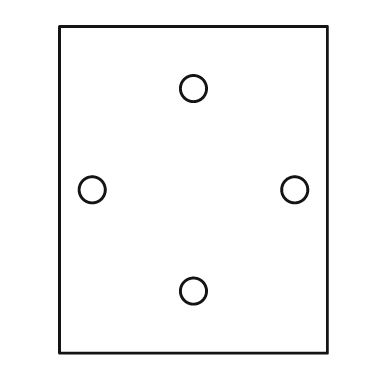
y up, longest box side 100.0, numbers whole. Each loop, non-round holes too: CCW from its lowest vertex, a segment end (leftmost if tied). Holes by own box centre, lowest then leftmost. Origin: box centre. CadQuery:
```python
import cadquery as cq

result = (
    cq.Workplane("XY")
    .moveTo(-41.0, -50.0)
    .lineTo(41.0, -50.0)
    .lineTo(41.0, 50.0)
    .lineTo(-41.0, 50.0)
    .close()
    .moveTo(0.0, -31.0)
    .circle(4.0)
    .moveTo(-31.0, 0.0)
    .circle(4.0)
    .moveTo(31.0, 0.0)
    .circle(4.0)
    .moveTo(0.0, 31.0)
    .circle(4.0)
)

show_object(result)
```